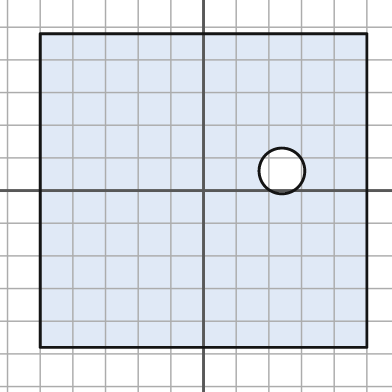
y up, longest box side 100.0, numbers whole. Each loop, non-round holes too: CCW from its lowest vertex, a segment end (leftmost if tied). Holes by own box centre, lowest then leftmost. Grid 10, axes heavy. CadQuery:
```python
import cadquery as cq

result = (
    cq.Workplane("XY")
    .moveTo(-50.0, -48.0)
    .lineTo(50.0, -48.0)
    .lineTo(50.0, 48.0)
    .lineTo(-50.0, 48.0)
    .close()
    .moveTo(24.0, 6.0)
    .circle(7.0)
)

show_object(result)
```